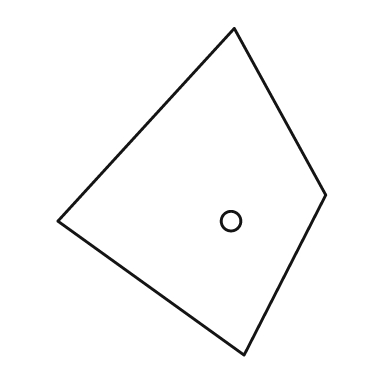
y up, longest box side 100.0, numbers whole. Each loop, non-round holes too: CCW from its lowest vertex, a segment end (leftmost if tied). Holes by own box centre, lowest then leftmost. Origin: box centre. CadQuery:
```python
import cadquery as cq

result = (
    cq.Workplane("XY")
    .moveTo(16.0, -50.0)
    .lineTo(41.0, -1.0)
    .lineTo(13.0, 50.0)
    .lineTo(-41.0, -9.0)
    .close()
    .moveTo(12.0, -9.0)
    .circle(3.0)
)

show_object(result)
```